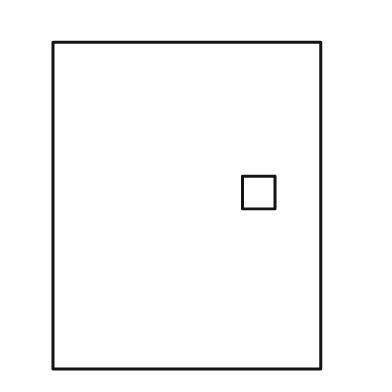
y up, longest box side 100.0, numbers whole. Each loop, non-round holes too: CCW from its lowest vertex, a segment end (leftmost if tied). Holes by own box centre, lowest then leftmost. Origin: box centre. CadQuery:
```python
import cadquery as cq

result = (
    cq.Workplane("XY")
    .moveTo(-41.0, -50.0)
    .lineTo(41.0, -50.0)
    .lineTo(41.0, 50.0)
    .lineTo(-41.0, 50.0)
    .close()
    .moveTo(17.0, -1.0)
    .lineTo(27.0, -1.0)
    .lineTo(27.0, 9.0)
    .lineTo(17.0, 9.0)
    .close()
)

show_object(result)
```